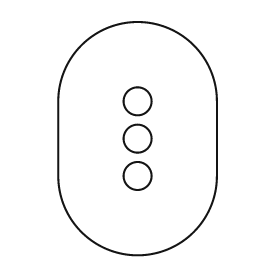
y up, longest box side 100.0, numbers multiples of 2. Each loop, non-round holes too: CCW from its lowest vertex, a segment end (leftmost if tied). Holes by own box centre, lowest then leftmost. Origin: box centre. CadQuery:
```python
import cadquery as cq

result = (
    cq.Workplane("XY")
    .moveTo(-34.0, -16.0)
    .threePointArc((0.0, -50.0), (34.0, -16.0))
    .lineTo(34.0, 16.0)
    .threePointArc((0.0, 50.0), (-34.0, 16.0))
    .close()
    .moveTo(0.0, -16.0)
    .circle(6.0)
    .moveTo(0.0, 0.0)
    .circle(6.0)
    .moveTo(0.0, 16.0)
    .circle(6.0)
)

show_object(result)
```